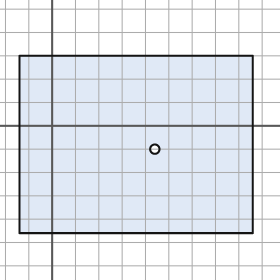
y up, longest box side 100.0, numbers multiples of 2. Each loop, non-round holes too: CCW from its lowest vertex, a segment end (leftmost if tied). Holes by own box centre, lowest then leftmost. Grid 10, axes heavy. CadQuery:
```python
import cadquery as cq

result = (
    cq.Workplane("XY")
    .moveTo(-14.0, -46.0)
    .lineTo(86.0, -46.0)
    .lineTo(86.0, 30.0)
    .lineTo(-14.0, 30.0)
    .close()
    .moveTo(44.0, -10.0)
    .circle(2.0)
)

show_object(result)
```